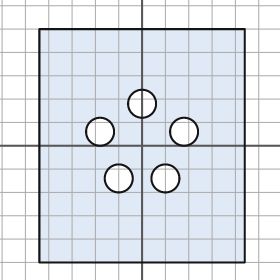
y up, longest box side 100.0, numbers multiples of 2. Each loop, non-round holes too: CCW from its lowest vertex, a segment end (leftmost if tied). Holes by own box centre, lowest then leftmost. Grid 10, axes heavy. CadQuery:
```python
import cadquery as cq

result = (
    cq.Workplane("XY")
    .moveTo(-44.0, -50.0)
    .lineTo(44.0, -50.0)
    .lineTo(44.0, 50.0)
    .lineTo(-44.0, 50.0)
    .close()
    .moveTo(-10.0, -14.0)
    .circle(6.0)
    .moveTo(10.0, -14.0)
    .circle(6.0)
    .moveTo(-18.0, 6.0)
    .circle(6.0)
    .moveTo(18.0, 6.0)
    .circle(6.0)
    .moveTo(0.0, 18.0)
    .circle(6.0)
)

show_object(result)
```